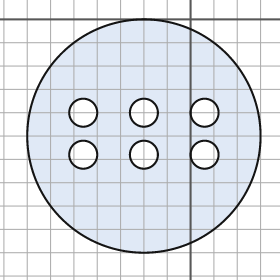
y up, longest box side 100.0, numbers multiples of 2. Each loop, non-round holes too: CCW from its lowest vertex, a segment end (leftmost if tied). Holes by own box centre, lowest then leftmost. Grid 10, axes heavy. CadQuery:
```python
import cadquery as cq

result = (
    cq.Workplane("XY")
    .moveTo(-20.0, -50.0)
    .circle(50.0)
    .moveTo(-46.0, -58.0)
    .circle(6.0)
    .moveTo(-20.0, -58.0)
    .circle(6.0)
    .moveTo(6.0, -58.0)
    .circle(6.0)
    .moveTo(-46.0, -40.0)
    .circle(6.0)
    .moveTo(-20.0, -40.0)
    .circle(6.0)
    .moveTo(6.0, -40.0)
    .circle(6.0)
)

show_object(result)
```